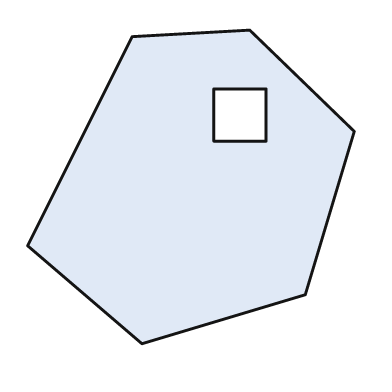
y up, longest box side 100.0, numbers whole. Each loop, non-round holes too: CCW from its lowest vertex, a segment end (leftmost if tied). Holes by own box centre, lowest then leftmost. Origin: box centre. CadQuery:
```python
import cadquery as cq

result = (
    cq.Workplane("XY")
    .moveTo(-15.0, -48.0)
    .lineTo(35.0, -33.0)
    .lineTo(50.0, 17.0)
    .lineTo(18.0, 48.0)
    .lineTo(-18.0, 46.0)
    .lineTo(-50.0, -18.0)
    .close()
    .moveTo(7.0, 14.0)
    .lineTo(23.0, 14.0)
    .lineTo(23.0, 30.0)
    .lineTo(7.0, 30.0)
    .close()
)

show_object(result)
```